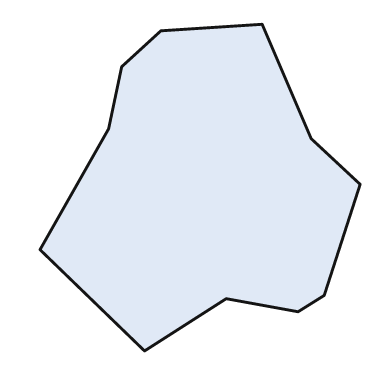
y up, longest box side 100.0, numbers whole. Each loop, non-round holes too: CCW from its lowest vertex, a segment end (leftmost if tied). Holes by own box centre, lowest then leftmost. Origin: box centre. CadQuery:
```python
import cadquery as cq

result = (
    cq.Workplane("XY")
    .moveTo(-17.0, -50.0)
    .lineTo(8.0, -34.0)
    .lineTo(30.0, -38.0)
    .lineTo(38.0, -33.0)
    .lineTo(49.0, 1.0)
    .lineTo(34.0, 15.0)
    .lineTo(19.0, 50.0)
    .lineTo(-12.0, 48.0)
    .lineTo(-24.0, 37.0)
    .lineTo(-28.0, 18.0)
    .lineTo(-49.0, -19.0)
    .close()
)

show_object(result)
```